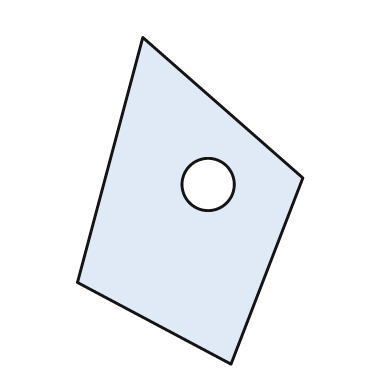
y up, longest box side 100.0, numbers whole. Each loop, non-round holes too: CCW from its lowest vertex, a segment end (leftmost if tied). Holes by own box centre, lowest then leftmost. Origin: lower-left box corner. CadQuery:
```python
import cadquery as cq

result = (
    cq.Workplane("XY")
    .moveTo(47.0, 0.0)
    .lineTo(69.0, 57.0)
    .lineTo(20.0, 100.0)
    .lineTo(0.0, 25.0)
    .close()
    .moveTo(40.0, 55.0)
    .circle(8.0)
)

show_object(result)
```